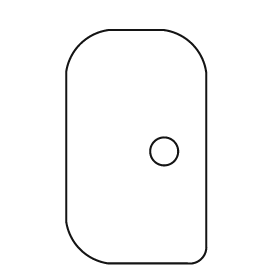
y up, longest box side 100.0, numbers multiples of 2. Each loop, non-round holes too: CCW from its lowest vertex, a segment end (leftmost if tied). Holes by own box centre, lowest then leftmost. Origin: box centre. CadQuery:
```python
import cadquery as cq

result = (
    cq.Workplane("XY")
    .moveTo(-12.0, -50.0)
    .lineTo(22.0, -50.0)
    .threePointArc((28.0, -48.0), (30.0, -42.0))
    .lineTo(30.0, 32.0)
    .threePointArc((24.0, 44.0), (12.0, 50.0))
    .lineTo(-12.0, 50.0)
    .threePointArc((-24.0, 44.0), (-30.0, 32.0))
    .lineTo(-30.0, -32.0)
    .threePointArc((-24.0, -44.0), (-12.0, -50.0))
    .close()
    .moveTo(12.0, -2.0)
    .circle(6.0)
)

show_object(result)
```